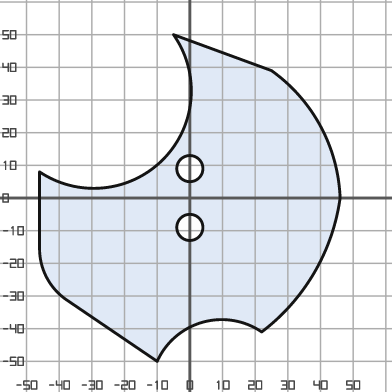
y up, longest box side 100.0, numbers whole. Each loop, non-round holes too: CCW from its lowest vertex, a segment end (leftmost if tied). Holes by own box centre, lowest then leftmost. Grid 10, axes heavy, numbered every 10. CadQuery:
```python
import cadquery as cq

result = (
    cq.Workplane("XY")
    .moveTo(-10.0, -50.0)
    .threePointArc((4.0, -38.0), (22.0, -41.0))
    .threePointArc((38.0, -23.0), (46.0, 0.0))
    .threePointArc((40.0, 22.0), (25.0, 39.0))
    .lineTo(-5.0, 50.0)
    .threePointArc((-8.0, 12.0), (-46.0, 8.0))
    .lineTo(-46.0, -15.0)
    .threePointArc((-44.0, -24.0), (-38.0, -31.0))
    .close()
    .moveTo(0.0, -9.0)
    .circle(4.0)
    .moveTo(0.0, 9.0)
    .circle(4.0)
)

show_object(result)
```